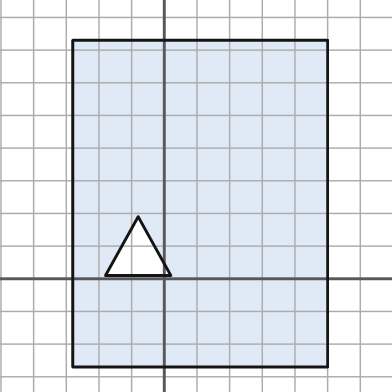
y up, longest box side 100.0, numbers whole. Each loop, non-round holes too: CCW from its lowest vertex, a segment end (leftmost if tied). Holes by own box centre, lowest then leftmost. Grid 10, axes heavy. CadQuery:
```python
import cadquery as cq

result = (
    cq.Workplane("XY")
    .moveTo(-28.0, -27.0)
    .lineTo(50.0, -27.0)
    .lineTo(50.0, 73.0)
    .lineTo(-28.0, 73.0)
    .close()
    .moveTo(-18.0, 1.0)
    .lineTo(2.0, 1.0)
    .lineTo(-8.0, 19.0)
    .close()
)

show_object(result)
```